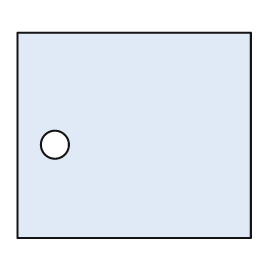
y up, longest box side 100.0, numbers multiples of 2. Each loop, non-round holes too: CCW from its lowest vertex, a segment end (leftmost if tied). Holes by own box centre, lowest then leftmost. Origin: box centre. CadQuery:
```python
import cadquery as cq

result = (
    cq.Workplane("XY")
    .moveTo(-50.0, -44.0)
    .lineTo(50.0, -44.0)
    .lineTo(50.0, 44.0)
    .lineTo(-50.0, 44.0)
    .close()
    .moveTo(-34.0, -4.0)
    .circle(6.0)
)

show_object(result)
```